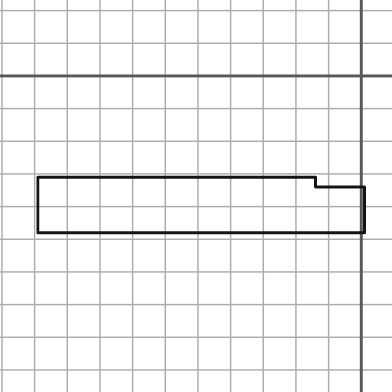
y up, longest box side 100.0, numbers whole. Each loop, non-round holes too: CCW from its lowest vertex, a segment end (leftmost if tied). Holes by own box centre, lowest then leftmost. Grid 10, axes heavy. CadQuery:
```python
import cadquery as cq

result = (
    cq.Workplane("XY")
    .moveTo(-99.0, -48.0)
    .lineTo(1.0, -48.0)
    .lineTo(1.0, -34.0)
    .lineTo(-14.0, -34.0)
    .lineTo(-14.0, -31.0)
    .lineTo(-99.0, -31.0)
    .close()
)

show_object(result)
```